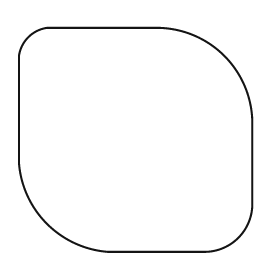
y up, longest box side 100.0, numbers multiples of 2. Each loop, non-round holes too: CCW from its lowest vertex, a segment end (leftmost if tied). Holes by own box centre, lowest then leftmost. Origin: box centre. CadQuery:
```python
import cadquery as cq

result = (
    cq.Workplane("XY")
    .moveTo(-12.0, -48.0)
    .lineTo(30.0, -48.0)
    .threePointArc((44.0, -42.0), (50.0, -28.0))
    .lineTo(50.0, 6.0)
    .threePointArc((38.0, 36.0), (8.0, 48.0))
    .lineTo(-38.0, 48.0)
    .threePointArc((-46.0, 44.0), (-50.0, 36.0))
    .lineTo(-50.0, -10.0)
    .threePointArc((-38.0, -36.0), (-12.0, -48.0))
    .close()
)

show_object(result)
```